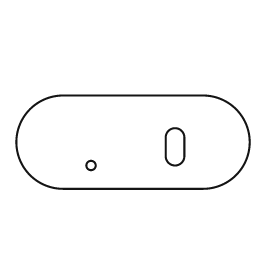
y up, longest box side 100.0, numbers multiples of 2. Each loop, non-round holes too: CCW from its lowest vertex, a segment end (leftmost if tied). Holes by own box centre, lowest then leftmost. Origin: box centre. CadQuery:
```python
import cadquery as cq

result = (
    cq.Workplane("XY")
    .moveTo(-30.0, -20.0)
    .lineTo(30.0, -20.0)
    .threePointArc((50.0, 0.0), (30.0, 20.0))
    .lineTo(-30.0, 20.0)
    .threePointArc((-50.0, 0.0), (-30.0, -20.0))
    .close()
    .moveTo(-18.0, -10.0)
    .circle(2.0)
    .moveTo(14.0, -6.0)
    .threePointArc((18.0, -10.0), (22.0, -6.0))
    .lineTo(22.0, 2.0)
    .threePointArc((18.0, 6.0), (14.0, 2.0))
    .close()
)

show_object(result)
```